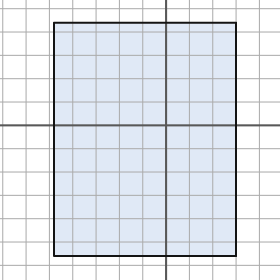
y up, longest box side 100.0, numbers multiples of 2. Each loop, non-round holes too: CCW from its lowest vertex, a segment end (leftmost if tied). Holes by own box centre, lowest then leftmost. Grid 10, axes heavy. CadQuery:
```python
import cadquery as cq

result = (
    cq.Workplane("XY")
    .moveTo(-48.0, -56.0)
    .lineTo(30.0, -56.0)
    .lineTo(30.0, 44.0)
    .lineTo(-48.0, 44.0)
    .close()
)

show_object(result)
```